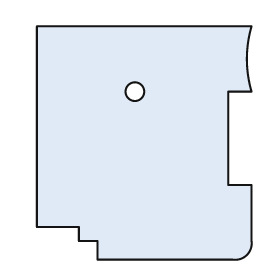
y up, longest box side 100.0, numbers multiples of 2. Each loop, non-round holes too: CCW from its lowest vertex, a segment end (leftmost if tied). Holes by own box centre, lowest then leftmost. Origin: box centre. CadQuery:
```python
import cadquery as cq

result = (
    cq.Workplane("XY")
    .moveTo(-20.0, -50.0)
    .lineTo(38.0, -50.0)
    .threePointArc((44.0, -48.0), (46.0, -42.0))
    .lineTo(46.0, -18.0)
    .lineTo(36.0, -18.0)
    .lineTo(36.0, 22.0)
    .lineTo(46.0, 22.0)
    .threePointArc((44.0, 36.0), (46.0, 50.0))
    .lineTo(-46.0, 50.0)
    .lineTo(-46.0, -36.0)
    .lineTo(-28.0, -36.0)
    .lineTo(-28.0, -42.0)
    .lineTo(-20.0, -42.0)
    .close()
    .moveTo(-4.0, 22.0)
    .circle(4.0)
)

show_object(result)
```